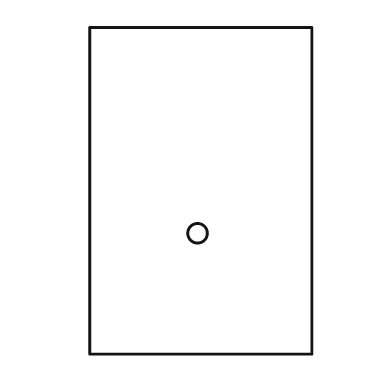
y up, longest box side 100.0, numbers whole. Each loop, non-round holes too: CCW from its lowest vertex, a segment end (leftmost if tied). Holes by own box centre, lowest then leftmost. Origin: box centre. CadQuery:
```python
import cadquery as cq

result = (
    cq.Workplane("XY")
    .moveTo(-34.0, -50.0)
    .lineTo(34.0, -50.0)
    .lineTo(34.0, 50.0)
    .lineTo(-34.0, 50.0)
    .close()
    .moveTo(-1.0, -13.0)
    .circle(3.0)
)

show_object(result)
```